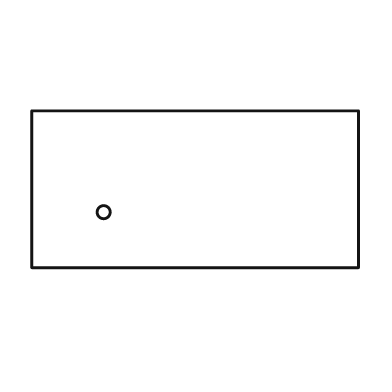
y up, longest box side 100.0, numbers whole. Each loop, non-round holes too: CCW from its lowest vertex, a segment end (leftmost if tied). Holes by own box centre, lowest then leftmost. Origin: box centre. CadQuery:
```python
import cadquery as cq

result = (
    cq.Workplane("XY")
    .moveTo(-50.0, -24.0)
    .lineTo(50.0, -24.0)
    .lineTo(50.0, 24.0)
    .lineTo(-50.0, 24.0)
    .close()
    .moveTo(-28.0, -7.0)
    .circle(2.0)
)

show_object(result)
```